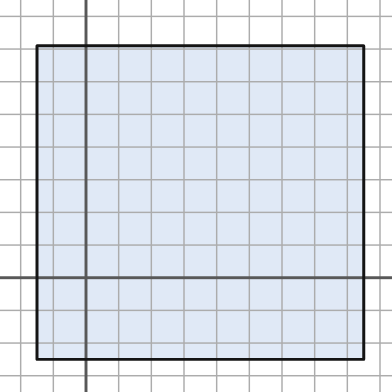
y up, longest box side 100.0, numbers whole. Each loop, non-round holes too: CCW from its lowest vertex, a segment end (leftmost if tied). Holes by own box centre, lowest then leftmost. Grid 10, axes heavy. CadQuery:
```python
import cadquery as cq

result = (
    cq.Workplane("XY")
    .moveTo(-15.0, -25.0)
    .lineTo(85.0, -25.0)
    .lineTo(85.0, 71.0)
    .lineTo(-15.0, 71.0)
    .close()
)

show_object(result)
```